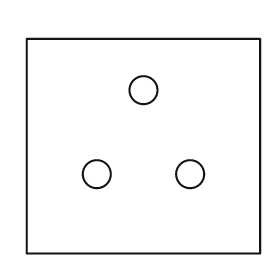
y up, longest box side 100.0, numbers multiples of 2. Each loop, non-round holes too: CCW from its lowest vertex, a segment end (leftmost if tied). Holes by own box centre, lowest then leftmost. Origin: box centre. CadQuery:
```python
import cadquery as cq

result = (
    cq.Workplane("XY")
    .moveTo(-50.0, -46.0)
    .lineTo(50.0, -46.0)
    .lineTo(50.0, 46.0)
    .lineTo(-50.0, 46.0)
    .close()
    .moveTo(-20.0, -12.0)
    .circle(6.0)
    .moveTo(20.0, -12.0)
    .circle(6.0)
    .moveTo(0.0, 24.0)
    .circle(6.0)
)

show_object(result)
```